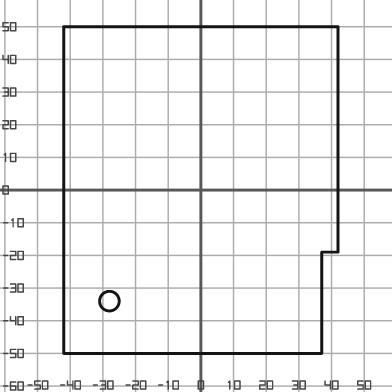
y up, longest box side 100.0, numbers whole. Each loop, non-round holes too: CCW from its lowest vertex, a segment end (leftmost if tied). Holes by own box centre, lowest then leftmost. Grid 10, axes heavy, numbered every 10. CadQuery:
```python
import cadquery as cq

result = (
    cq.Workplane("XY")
    .moveTo(-42.0, -50.0)
    .lineTo(37.0, -50.0)
    .lineTo(37.0, -19.0)
    .lineTo(42.0, -19.0)
    .lineTo(42.0, 50.0)
    .lineTo(-42.0, 50.0)
    .close()
    .moveTo(-28.0, -34.0)
    .circle(3.0)
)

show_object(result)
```